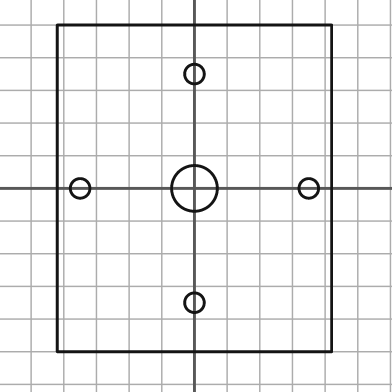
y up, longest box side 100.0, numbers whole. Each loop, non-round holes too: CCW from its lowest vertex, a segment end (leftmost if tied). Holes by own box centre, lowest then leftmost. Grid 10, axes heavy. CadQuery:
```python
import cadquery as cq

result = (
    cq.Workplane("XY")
    .moveTo(-42.0, -50.0)
    .lineTo(42.0, -50.0)
    .lineTo(42.0, 50.0)
    .lineTo(-42.0, 50.0)
    .close()
    .moveTo(0.0, -35.0)
    .circle(3.0)
    .moveTo(-35.0, 0.0)
    .circle(3.0)
    .moveTo(0.0, 0.0)
    .circle(7.0)
    .moveTo(35.0, 0.0)
    .circle(3.0)
    .moveTo(0.0, 35.0)
    .circle(3.0)
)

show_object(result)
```